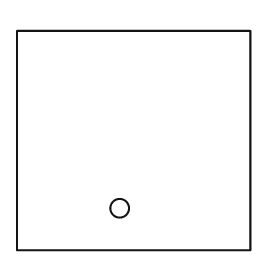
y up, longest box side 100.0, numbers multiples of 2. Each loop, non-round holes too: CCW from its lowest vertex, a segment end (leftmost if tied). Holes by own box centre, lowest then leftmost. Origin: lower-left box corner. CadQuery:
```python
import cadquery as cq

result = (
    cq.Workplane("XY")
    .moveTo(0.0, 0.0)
    .lineTo(100.0, 0.0)
    .lineTo(100.0, 94.0)
    .lineTo(0.0, 94.0)
    .close()
    .moveTo(44.0, 18.0)
    .circle(4.0)
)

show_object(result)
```